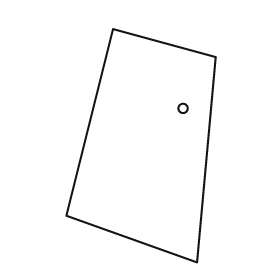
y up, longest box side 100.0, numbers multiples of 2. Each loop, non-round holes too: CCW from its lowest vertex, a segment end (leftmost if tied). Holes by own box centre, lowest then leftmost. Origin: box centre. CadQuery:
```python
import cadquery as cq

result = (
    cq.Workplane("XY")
    .moveTo(24.0, -50.0)
    .lineTo(32.0, 38.0)
    .lineTo(-12.0, 50.0)
    .lineTo(-32.0, -30.0)
    .close()
    .moveTo(18.0, 16.0)
    .circle(2.0)
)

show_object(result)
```